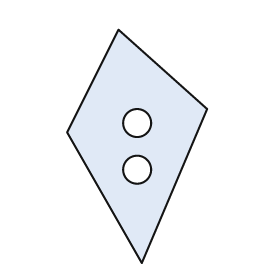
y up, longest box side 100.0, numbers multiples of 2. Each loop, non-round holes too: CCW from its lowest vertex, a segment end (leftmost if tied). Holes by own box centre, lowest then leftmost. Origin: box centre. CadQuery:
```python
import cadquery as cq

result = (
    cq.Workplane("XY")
    .moveTo(2.0, -50.0)
    .lineTo(30.0, 16.0)
    .lineTo(-8.0, 50.0)
    .lineTo(-30.0, 6.0)
    .close()
    .moveTo(0.0, -10.0)
    .circle(6.0)
    .moveTo(0.0, 10.0)
    .circle(6.0)
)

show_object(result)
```